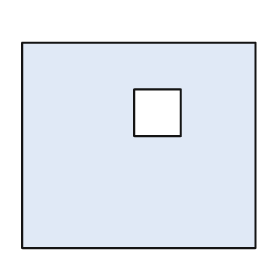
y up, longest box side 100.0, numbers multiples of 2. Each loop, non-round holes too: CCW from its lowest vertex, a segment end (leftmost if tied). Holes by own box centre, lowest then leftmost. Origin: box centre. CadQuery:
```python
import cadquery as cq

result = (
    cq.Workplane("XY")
    .moveTo(-50.0, -44.0)
    .lineTo(50.0, -44.0)
    .lineTo(50.0, 44.0)
    .lineTo(-50.0, 44.0)
    .close()
    .moveTo(-2.0, 4.0)
    .lineTo(18.0, 4.0)
    .lineTo(18.0, 24.0)
    .lineTo(-2.0, 24.0)
    .close()
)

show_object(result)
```